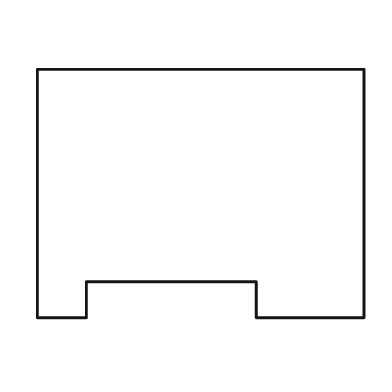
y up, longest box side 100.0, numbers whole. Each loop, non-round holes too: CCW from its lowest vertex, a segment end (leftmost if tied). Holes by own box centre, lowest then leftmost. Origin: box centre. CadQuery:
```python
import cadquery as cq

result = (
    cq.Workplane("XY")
    .moveTo(-50.0, -38.0)
    .lineTo(-35.0, -38.0)
    .lineTo(-35.0, -27.0)
    .lineTo(17.0, -27.0)
    .lineTo(17.0, -38.0)
    .lineTo(50.0, -38.0)
    .lineTo(50.0, 38.0)
    .lineTo(-50.0, 38.0)
    .close()
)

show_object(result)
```